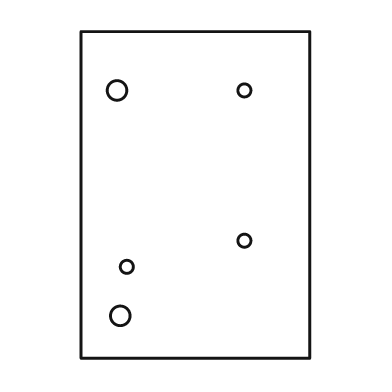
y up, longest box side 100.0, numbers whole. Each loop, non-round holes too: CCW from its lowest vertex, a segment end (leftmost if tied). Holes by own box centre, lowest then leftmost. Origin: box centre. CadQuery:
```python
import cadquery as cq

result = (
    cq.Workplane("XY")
    .moveTo(-35.0, -50.0)
    .lineTo(35.0, -50.0)
    .lineTo(35.0, 50.0)
    .lineTo(-35.0, 50.0)
    .close()
    .moveTo(-23.0, -37.0)
    .circle(3.0)
    .moveTo(-21.0, -22.0)
    .circle(2.0)
    .moveTo(15.0, -14.0)
    .circle(2.0)
    .moveTo(-24.0, 32.0)
    .circle(3.0)
    .moveTo(15.0, 32.0)
    .circle(2.0)
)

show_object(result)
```